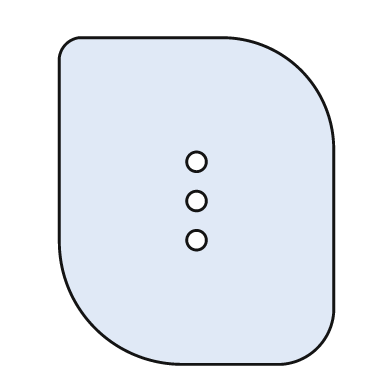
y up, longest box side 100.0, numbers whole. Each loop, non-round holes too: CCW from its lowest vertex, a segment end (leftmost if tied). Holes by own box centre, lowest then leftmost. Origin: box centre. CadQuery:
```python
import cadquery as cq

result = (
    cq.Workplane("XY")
    .moveTo(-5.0, -50.0)
    .lineTo(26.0, -50.0)
    .threePointArc((37.0, -45.0), (42.0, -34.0))
    .lineTo(42.0, 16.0)
    .threePointArc((32.0, 40.0), (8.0, 50.0))
    .lineTo(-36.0, 50.0)
    .threePointArc((-40.0, 48.0), (-42.0, 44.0))
    .lineTo(-42.0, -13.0)
    .threePointArc((-31.0, -39.0), (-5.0, -50.0))
    .close()
    .moveTo(0.0, -12.0)
    .circle(3.0)
    .moveTo(0.0, 0.0)
    .circle(3.0)
    .moveTo(0.0, 12.0)
    .circle(3.0)
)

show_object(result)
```